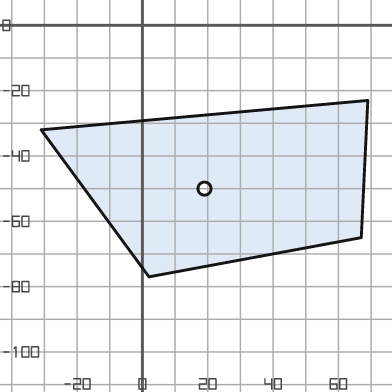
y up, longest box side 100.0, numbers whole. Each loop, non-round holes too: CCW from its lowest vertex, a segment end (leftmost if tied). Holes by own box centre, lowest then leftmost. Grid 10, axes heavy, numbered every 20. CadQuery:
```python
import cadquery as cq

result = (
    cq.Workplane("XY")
    .moveTo(2.0, -77.0)
    .lineTo(67.0, -65.0)
    .lineTo(69.0, -23.0)
    .lineTo(-31.0, -32.0)
    .close()
    .moveTo(19.0, -50.0)
    .circle(2.0)
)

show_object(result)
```